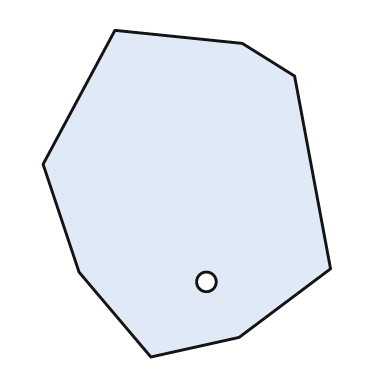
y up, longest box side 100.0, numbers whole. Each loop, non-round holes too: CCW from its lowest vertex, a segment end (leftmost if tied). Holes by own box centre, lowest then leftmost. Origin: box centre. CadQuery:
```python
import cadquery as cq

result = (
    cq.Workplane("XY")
    .moveTo(-11.0, -50.0)
    .lineTo(16.0, -44.0)
    .lineTo(44.0, -23.0)
    .lineTo(33.0, 36.0)
    .lineTo(17.0, 46.0)
    .lineTo(-22.0, 50.0)
    .lineTo(-44.0, 9.0)
    .lineTo(-33.0, -24.0)
    .close()
    .moveTo(6.0, -27.0)
    .circle(3.0)
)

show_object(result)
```